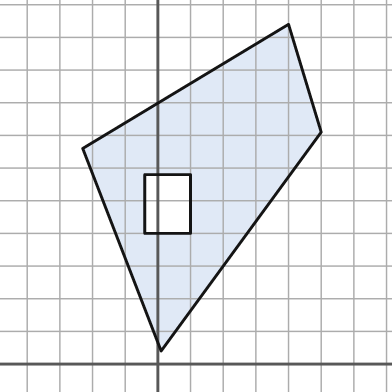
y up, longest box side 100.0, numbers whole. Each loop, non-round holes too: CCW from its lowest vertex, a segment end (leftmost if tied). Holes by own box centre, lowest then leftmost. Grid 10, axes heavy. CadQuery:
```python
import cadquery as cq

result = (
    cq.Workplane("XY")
    .moveTo(1.0, 4.0)
    .lineTo(50.0, 71.0)
    .lineTo(40.0, 104.0)
    .lineTo(-23.0, 66.0)
    .close()
    .moveTo(-4.0, 40.0)
    .lineTo(10.0, 40.0)
    .lineTo(10.0, 58.0)
    .lineTo(-4.0, 58.0)
    .close()
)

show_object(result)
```